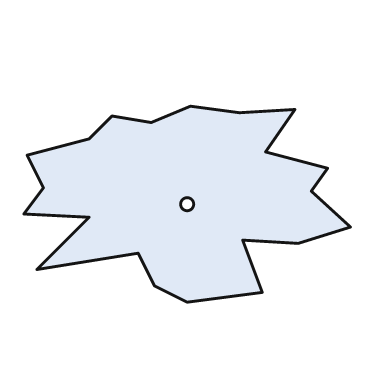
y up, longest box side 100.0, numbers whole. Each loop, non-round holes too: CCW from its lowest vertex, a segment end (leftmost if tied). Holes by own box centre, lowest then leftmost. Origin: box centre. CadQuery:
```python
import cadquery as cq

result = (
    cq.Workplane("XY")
    .moveTo(0.0, -30.0)
    .lineTo(23.0, -27.0)
    .lineTo(17.0, -11.0)
    .lineTo(34.0, -12.0)
    .lineTo(50.0, -7.0)
    .lineTo(38.0, 4.0)
    .lineTo(43.0, 11.0)
    .lineTo(24.0, 16.0)
    .lineTo(33.0, 29.0)
    .lineTo(16.0, 28.0)
    .lineTo(1.0, 30.0)
    .lineTo(-11.0, 25.0)
    .lineTo(-23.0, 27.0)
    .lineTo(-30.0, 20.0)
    .lineTo(-49.0, 15.0)
    .lineTo(-44.0, 5.0)
    .lineTo(-50.0, -3.0)
    .lineTo(-30.0, -4.0)
    .lineTo(-46.0, -20.0)
    .lineTo(-15.0, -15.0)
    .lineTo(-10.0, -25.0)
    .close()
    .moveTo(0.0, 0.0)
    .circle(2.0)
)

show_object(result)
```